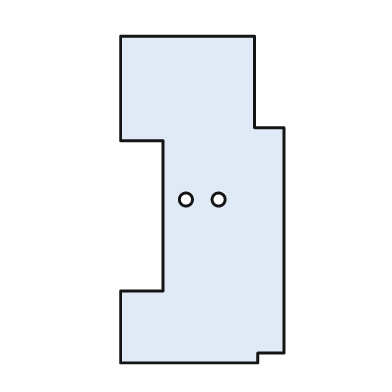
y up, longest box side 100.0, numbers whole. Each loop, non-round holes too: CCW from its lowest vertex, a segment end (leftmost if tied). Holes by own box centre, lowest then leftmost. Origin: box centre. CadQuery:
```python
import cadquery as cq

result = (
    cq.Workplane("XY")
    .moveTo(-25.0, -50.0)
    .lineTo(17.0, -50.0)
    .lineTo(17.0, -47.0)
    .lineTo(25.0, -47.0)
    .lineTo(25.0, 22.0)
    .lineTo(16.0, 22.0)
    .lineTo(16.0, 50.0)
    .lineTo(-25.0, 50.0)
    .lineTo(-25.0, 18.0)
    .lineTo(-12.0, 18.0)
    .lineTo(-12.0, -28.0)
    .lineTo(-25.0, -28.0)
    .close()
    .moveTo(-5.0, 0.0)
    .circle(2.0)
    .moveTo(5.0, 0.0)
    .circle(2.0)
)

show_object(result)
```